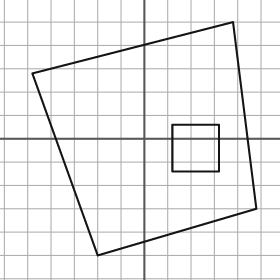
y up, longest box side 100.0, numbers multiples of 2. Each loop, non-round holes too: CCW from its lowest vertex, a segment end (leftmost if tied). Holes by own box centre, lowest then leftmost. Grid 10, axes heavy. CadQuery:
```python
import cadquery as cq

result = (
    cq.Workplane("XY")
    .moveTo(-20.0, -50.0)
    .lineTo(48.0, -30.0)
    .lineTo(38.0, 50.0)
    .lineTo(-48.0, 28.0)
    .close()
    .moveTo(12.0, -14.0)
    .lineTo(32.0, -14.0)
    .lineTo(32.0, 6.0)
    .lineTo(12.0, 6.0)
    .close()
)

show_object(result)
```